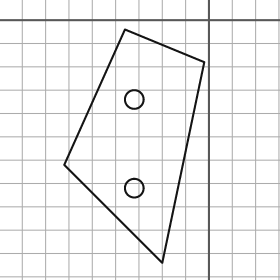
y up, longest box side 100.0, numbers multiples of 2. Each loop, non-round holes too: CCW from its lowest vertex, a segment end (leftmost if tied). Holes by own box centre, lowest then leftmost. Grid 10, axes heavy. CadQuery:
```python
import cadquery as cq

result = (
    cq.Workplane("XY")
    .moveTo(-20.0, -104.0)
    .lineTo(-2.0, -18.0)
    .lineTo(-36.0, -4.0)
    .lineTo(-62.0, -62.0)
    .close()
    .moveTo(-32.0, -72.0)
    .circle(4.0)
    .moveTo(-32.0, -34.0)
    .circle(4.0)
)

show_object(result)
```